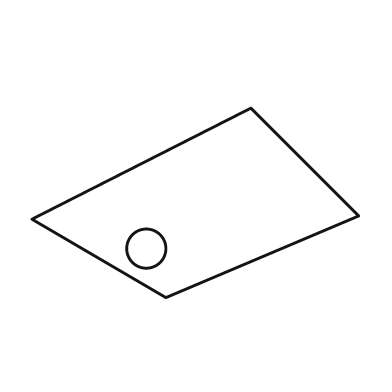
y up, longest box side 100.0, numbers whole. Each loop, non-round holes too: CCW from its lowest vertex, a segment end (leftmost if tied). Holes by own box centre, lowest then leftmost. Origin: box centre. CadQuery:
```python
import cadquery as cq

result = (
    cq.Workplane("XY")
    .moveTo(-9.0, -29.0)
    .lineTo(50.0, -4.0)
    .lineTo(17.0, 29.0)
    .lineTo(-50.0, -5.0)
    .close()
    .moveTo(-15.0, -14.0)
    .circle(6.0)
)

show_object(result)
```